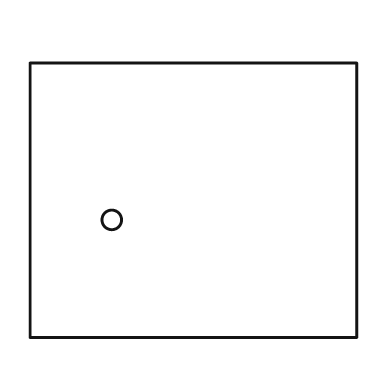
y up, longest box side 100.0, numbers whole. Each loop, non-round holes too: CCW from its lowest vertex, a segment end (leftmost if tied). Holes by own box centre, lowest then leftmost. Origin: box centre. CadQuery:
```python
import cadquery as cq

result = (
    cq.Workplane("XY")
    .moveTo(-50.0, -42.0)
    .lineTo(50.0, -42.0)
    .lineTo(50.0, 42.0)
    .lineTo(-50.0, 42.0)
    .close()
    .moveTo(-25.0, -6.0)
    .circle(3.0)
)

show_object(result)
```